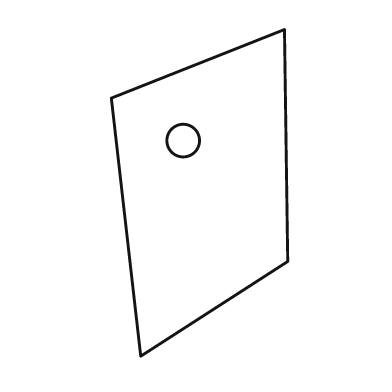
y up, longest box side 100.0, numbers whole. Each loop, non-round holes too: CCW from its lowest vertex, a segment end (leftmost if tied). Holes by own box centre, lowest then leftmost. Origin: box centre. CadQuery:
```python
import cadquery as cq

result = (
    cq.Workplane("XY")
    .moveTo(-18.0, -50.0)
    .lineTo(27.0, -21.0)
    .lineTo(26.0, 50.0)
    .lineTo(-27.0, 29.0)
    .close()
    .moveTo(-5.0, 16.0)
    .circle(5.0)
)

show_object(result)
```